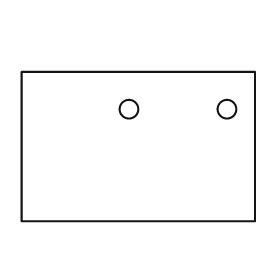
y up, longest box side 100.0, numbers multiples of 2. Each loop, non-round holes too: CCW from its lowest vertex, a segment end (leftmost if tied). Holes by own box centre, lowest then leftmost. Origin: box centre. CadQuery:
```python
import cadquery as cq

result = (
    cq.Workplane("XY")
    .moveTo(-50.0, -32.0)
    .lineTo(50.0, -32.0)
    .lineTo(50.0, 32.0)
    .lineTo(-50.0, 32.0)
    .close()
    .moveTo(-4.0, 16.0)
    .circle(4.0)
    .moveTo(38.0, 16.0)
    .circle(4.0)
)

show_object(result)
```